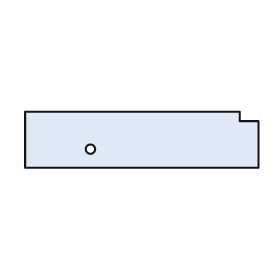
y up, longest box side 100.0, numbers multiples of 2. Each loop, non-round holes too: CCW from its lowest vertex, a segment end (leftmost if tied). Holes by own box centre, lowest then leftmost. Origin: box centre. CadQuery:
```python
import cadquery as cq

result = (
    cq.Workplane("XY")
    .moveTo(-50.0, -12.0)
    .lineTo(50.0, -12.0)
    .lineTo(50.0, 8.0)
    .lineTo(42.0, 8.0)
    .lineTo(42.0, 12.0)
    .lineTo(-50.0, 12.0)
    .close()
    .moveTo(-22.0, -4.0)
    .circle(2.0)
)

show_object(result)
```